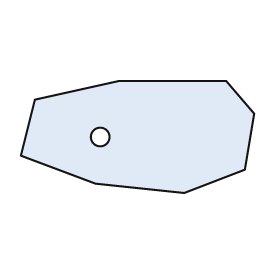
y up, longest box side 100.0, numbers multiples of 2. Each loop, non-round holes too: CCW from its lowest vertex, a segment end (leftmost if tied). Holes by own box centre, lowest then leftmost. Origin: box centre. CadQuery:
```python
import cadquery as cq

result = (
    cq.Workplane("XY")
    .moveTo(20.0, -24.0)
    .lineTo(46.0, -14.0)
    .lineTo(50.0, 10.0)
    .lineTo(38.0, 24.0)
    .lineTo(-8.0, 24.0)
    .lineTo(-44.0, 16.0)
    .lineTo(-50.0, -8.0)
    .lineTo(-18.0, -20.0)
    .close()
    .moveTo(-16.0, 0.0)
    .circle(4.0)
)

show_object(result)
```